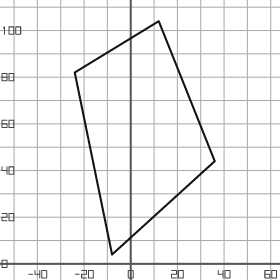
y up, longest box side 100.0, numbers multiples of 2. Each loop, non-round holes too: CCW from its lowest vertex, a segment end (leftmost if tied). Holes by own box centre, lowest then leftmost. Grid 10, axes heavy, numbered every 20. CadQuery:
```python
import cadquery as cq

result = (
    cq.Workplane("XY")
    .moveTo(-8.0, 4.0)
    .lineTo(36.0, 44.0)
    .lineTo(12.0, 104.0)
    .lineTo(-24.0, 82.0)
    .close()
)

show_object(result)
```